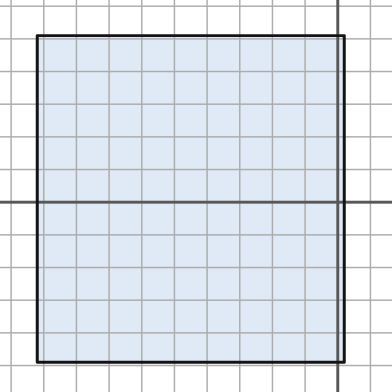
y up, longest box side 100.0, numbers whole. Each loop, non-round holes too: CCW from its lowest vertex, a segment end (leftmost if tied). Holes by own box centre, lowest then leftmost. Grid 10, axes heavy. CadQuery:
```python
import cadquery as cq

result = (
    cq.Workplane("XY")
    .moveTo(-92.0, -49.0)
    .lineTo(2.0, -49.0)
    .lineTo(2.0, 51.0)
    .lineTo(-92.0, 51.0)
    .close()
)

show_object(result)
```